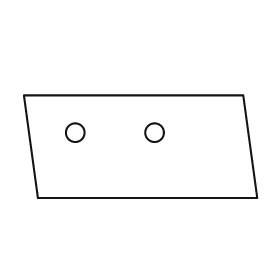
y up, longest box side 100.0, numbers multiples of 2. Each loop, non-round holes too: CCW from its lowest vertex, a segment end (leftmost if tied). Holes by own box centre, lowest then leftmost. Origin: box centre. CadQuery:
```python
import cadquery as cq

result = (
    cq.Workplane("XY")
    .moveTo(-44.0, -22.0)
    .lineTo(50.0, -22.0)
    .lineTo(44.0, 22.0)
    .lineTo(-50.0, 22.0)
    .close()
    .moveTo(-28.0, 6.0)
    .circle(4.0)
    .moveTo(6.0, 6.0)
    .circle(4.0)
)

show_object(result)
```